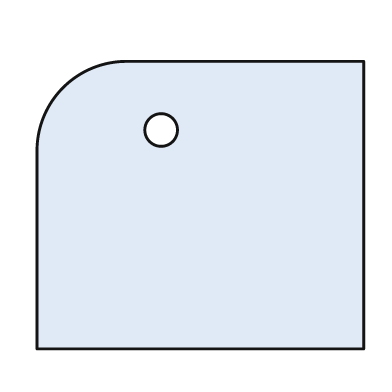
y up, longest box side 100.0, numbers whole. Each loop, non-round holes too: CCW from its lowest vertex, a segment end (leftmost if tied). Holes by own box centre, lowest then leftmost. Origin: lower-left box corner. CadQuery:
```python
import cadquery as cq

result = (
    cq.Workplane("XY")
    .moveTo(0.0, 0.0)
    .lineTo(100.0, 0.0)
    .lineTo(100.0, 88.0)
    .lineTo(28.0, 88.0)
    .threePointArc((8.0, 80.0), (0.0, 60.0))
    .close()
    .moveTo(38.0, 67.0)
    .circle(5.0)
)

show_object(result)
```